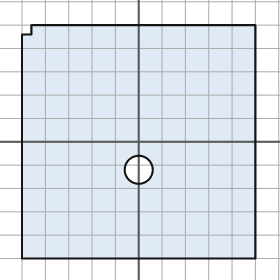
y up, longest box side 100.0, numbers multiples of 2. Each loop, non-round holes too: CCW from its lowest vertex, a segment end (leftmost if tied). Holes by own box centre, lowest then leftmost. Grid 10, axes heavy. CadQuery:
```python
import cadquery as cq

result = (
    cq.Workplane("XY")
    .moveTo(-50.0, -50.0)
    .lineTo(50.0, -50.0)
    .lineTo(50.0, 50.0)
    .lineTo(-46.0, 50.0)
    .lineTo(-46.0, 46.0)
    .lineTo(-50.0, 46.0)
    .close()
    .moveTo(0.0, -12.0)
    .circle(6.0)
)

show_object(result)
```